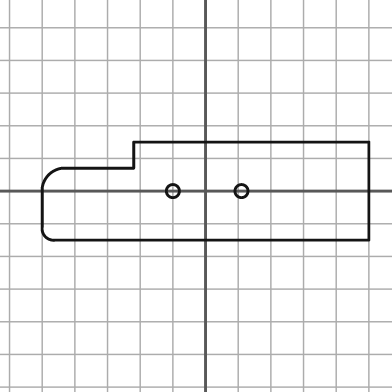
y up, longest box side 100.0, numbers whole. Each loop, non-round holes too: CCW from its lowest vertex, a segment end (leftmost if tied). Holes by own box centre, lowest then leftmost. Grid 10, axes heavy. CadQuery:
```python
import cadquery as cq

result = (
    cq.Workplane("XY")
    .moveTo(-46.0, -15.0)
    .lineTo(50.0, -15.0)
    .lineTo(50.0, 15.0)
    .lineTo(-22.0, 15.0)
    .lineTo(-22.0, 7.0)
    .lineTo(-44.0, 7.0)
    .threePointArc((-48.0, 5.0), (-50.0, 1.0))
    .lineTo(-50.0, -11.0)
    .threePointArc((-49.0, -14.0), (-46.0, -15.0))
    .close()
    .moveTo(-10.0, 0.0)
    .circle(2.0)
    .moveTo(11.0, 0.0)
    .circle(2.0)
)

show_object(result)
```